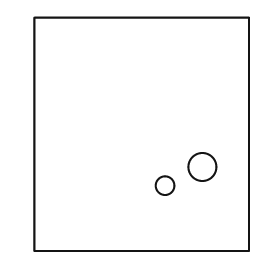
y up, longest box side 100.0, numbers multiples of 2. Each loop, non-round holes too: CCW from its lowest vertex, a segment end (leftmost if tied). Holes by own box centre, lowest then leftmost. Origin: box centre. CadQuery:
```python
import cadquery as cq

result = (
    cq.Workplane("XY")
    .moveTo(-46.0, -50.0)
    .lineTo(46.0, -50.0)
    .lineTo(46.0, 50.0)
    .lineTo(-46.0, 50.0)
    .close()
    .moveTo(10.0, -22.0)
    .circle(4.0)
    .moveTo(26.0, -14.0)
    .circle(6.0)
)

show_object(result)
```